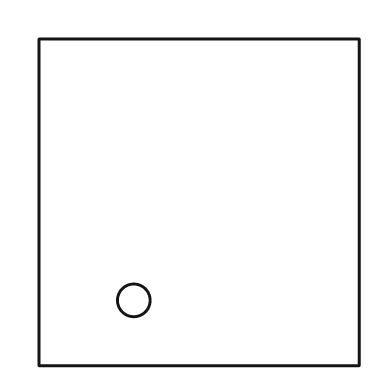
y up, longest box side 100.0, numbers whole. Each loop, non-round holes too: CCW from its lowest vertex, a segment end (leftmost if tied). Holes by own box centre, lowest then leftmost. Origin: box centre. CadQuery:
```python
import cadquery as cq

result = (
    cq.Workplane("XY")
    .moveTo(-49.0, -50.0)
    .lineTo(49.0, -50.0)
    .lineTo(49.0, 50.0)
    .lineTo(-49.0, 50.0)
    .close()
    .moveTo(-20.0, -30.0)
    .circle(5.0)
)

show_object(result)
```